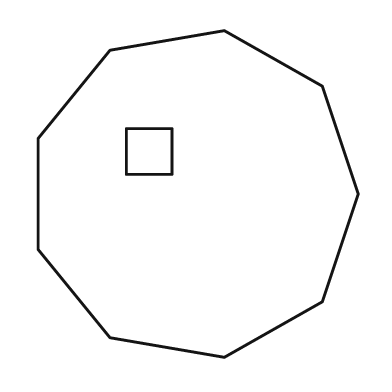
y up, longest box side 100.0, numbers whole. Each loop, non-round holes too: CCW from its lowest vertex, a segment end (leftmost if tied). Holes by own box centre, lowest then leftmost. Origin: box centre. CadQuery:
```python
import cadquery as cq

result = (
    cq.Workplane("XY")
    .moveTo(8.0, -50.0)
    .lineTo(38.0, -33.0)
    .lineTo(49.0, 0.0)
    .lineTo(38.0, 33.0)
    .lineTo(8.0, 50.0)
    .lineTo(-27.0, 44.0)
    .lineTo(-49.0, 17.0)
    .lineTo(-49.0, -17.0)
    .lineTo(-27.0, -44.0)
    .close()
    .moveTo(-22.0, 6.0)
    .lineTo(-8.0, 6.0)
    .lineTo(-8.0, 20.0)
    .lineTo(-22.0, 20.0)
    .close()
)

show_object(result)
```